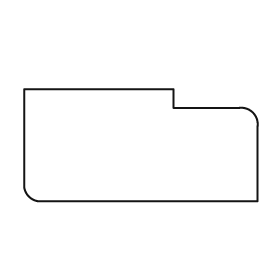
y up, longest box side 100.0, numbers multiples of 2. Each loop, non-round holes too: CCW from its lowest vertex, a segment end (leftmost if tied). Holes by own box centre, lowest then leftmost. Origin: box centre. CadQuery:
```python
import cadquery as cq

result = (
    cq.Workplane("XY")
    .moveTo(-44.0, -24.0)
    .lineTo(50.0, -24.0)
    .lineTo(50.0, 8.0)
    .threePointArc((48.0, 14.0), (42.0, 16.0))
    .lineTo(14.0, 16.0)
    .lineTo(14.0, 24.0)
    .lineTo(-50.0, 24.0)
    .lineTo(-50.0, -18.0)
    .threePointArc((-48.0, -22.0), (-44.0, -24.0))
    .close()
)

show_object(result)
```